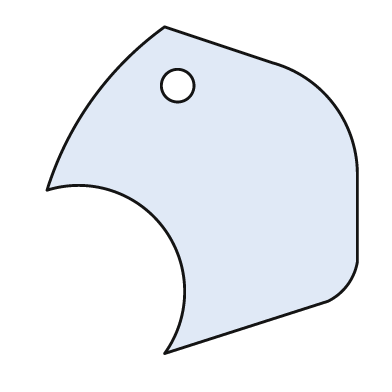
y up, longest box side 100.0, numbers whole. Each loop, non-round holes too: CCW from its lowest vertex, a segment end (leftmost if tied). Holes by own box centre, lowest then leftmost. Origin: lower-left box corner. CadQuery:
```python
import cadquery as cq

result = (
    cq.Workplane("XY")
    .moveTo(36.0, 0.0)
    .lineTo(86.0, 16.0)
    .threePointArc((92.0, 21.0), (95.0, 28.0))
    .lineTo(95.0, 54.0)
    .threePointArc((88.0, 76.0), (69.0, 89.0))
    .lineTo(36.0, 100.0)
    .threePointArc((14.0, 78.0), (0.0, 50.0))
    .threePointArc((36.0, 38.0), (36.0, 0.0))
    .close()
    .moveTo(40.0, 82.0)
    .circle(5.0)
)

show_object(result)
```